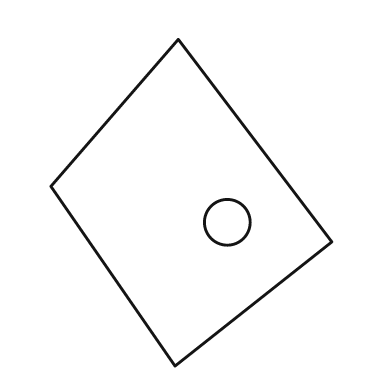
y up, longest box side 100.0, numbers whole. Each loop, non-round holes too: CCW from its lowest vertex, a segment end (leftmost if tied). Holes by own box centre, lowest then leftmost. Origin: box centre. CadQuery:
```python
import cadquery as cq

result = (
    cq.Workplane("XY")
    .moveTo(-5.0, -50.0)
    .lineTo(43.0, -12.0)
    .lineTo(-4.0, 50.0)
    .lineTo(-43.0, 5.0)
    .close()
    .moveTo(11.0, -6.0)
    .circle(7.0)
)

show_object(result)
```